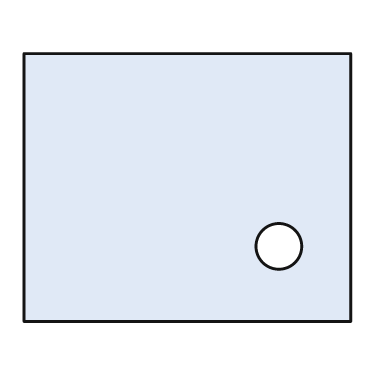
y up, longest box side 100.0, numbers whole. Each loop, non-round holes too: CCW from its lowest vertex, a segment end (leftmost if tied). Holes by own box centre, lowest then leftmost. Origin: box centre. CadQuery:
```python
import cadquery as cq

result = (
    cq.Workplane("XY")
    .moveTo(-50.0, -41.0)
    .lineTo(50.0, -41.0)
    .lineTo(50.0, 41.0)
    .lineTo(-50.0, 41.0)
    .close()
    .moveTo(28.0, -18.0)
    .circle(7.0)
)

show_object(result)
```